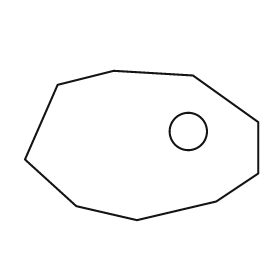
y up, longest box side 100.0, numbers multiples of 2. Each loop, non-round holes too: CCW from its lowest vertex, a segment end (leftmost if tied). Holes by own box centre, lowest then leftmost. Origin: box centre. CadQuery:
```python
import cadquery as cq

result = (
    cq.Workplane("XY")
    .moveTo(-2.0, -32.0)
    .lineTo(32.0, -24.0)
    .lineTo(50.0, -12.0)
    .lineTo(50.0, 10.0)
    .lineTo(22.0, 30.0)
    .lineTo(-12.0, 32.0)
    .lineTo(-36.0, 26.0)
    .lineTo(-50.0, -6.0)
    .lineTo(-28.0, -26.0)
    .close()
    .moveTo(20.0, 6.0)
    .circle(8.0)
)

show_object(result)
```